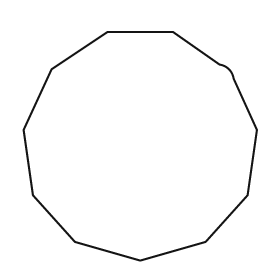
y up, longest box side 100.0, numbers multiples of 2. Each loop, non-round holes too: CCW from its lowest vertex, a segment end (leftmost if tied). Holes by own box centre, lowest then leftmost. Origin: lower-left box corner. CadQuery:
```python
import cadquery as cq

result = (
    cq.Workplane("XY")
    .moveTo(50.0, 0.0)
    .lineTo(78.0, 8.0)
    .lineTo(96.0, 28.0)
    .lineTo(100.0, 56.0)
    .lineTo(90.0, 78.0)
    .threePointArc((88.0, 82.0), (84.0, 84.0))
    .lineTo(64.0, 98.0)
    .lineTo(36.0, 98.0)
    .lineTo(12.0, 82.0)
    .lineTo(0.0, 56.0)
    .lineTo(4.0, 28.0)
    .lineTo(22.0, 8.0)
    .close()
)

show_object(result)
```